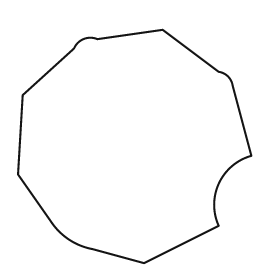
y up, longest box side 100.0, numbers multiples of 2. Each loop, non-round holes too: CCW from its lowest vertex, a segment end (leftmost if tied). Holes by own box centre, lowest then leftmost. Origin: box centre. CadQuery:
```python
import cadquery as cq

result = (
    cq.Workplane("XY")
    .moveTo(4.0, -50.0)
    .lineTo(36.0, -34.0)
    .threePointArc((36.0, -16.0), (50.0, -4.0))
    .lineTo(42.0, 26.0)
    .threePointArc((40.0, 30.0), (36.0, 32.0))
    .lineTo(12.0, 50.0)
    .lineTo(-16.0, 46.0)
    .threePointArc((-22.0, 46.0), (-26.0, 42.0))
    .lineTo(-48.0, 22.0)
    .lineTo(-50.0, -12.0)
    .lineTo(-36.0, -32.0)
    .threePointArc((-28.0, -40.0), (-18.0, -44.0))
    .close()
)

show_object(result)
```